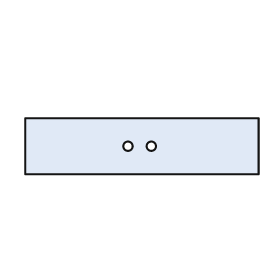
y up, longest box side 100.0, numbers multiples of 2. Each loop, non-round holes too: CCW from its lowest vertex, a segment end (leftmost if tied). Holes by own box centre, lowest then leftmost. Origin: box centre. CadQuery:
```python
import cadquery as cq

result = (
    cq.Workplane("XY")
    .moveTo(-50.0, -12.0)
    .lineTo(50.0, -12.0)
    .lineTo(50.0, 12.0)
    .lineTo(-50.0, 12.0)
    .close()
    .moveTo(-6.0, 0.0)
    .circle(2.0)
    .moveTo(4.0, 0.0)
    .circle(2.0)
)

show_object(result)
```